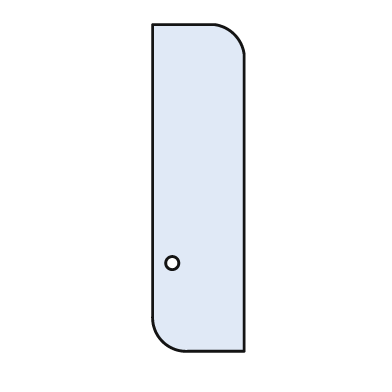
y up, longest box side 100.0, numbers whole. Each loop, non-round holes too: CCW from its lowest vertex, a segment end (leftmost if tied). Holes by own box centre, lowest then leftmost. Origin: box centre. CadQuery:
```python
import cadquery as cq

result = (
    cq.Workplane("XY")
    .moveTo(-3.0, -50.0)
    .lineTo(14.0, -50.0)
    .lineTo(14.0, 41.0)
    .threePointArc((11.0, 47.0), (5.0, 50.0))
    .lineTo(-14.0, 50.0)
    .lineTo(-14.0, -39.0)
    .threePointArc((-11.0, -47.0), (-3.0, -50.0))
    .close()
    .moveTo(-8.0, -23.0)
    .circle(2.0)
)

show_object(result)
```